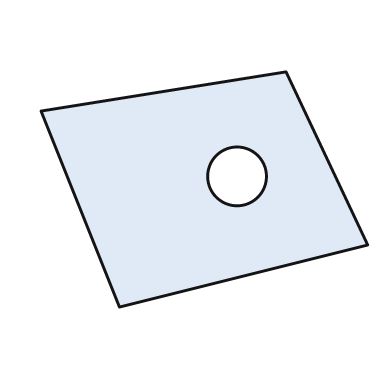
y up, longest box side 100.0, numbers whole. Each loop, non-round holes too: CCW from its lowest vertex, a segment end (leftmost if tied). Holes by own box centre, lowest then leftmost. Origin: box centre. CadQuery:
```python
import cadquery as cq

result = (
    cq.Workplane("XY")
    .moveTo(-26.0, -36.0)
    .lineTo(50.0, -17.0)
    .lineTo(25.0, 36.0)
    .lineTo(-50.0, 24.0)
    .close()
    .moveTo(10.0, 4.0)
    .circle(9.0)
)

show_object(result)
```